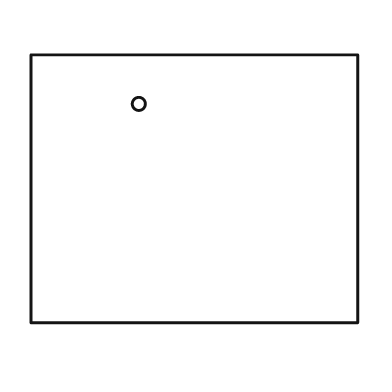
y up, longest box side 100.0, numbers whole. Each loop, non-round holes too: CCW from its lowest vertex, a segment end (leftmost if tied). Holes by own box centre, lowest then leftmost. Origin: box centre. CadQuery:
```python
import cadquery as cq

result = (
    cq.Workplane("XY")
    .moveTo(-50.0, -41.0)
    .lineTo(50.0, -41.0)
    .lineTo(50.0, 41.0)
    .lineTo(-50.0, 41.0)
    .close()
    .moveTo(-17.0, 26.0)
    .circle(2.0)
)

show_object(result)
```